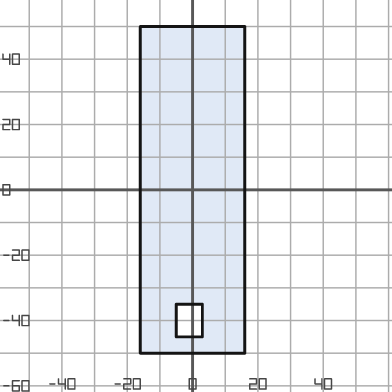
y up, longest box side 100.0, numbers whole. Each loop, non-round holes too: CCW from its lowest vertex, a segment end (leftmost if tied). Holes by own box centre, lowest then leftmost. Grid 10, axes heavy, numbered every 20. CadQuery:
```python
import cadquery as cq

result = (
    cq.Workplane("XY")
    .moveTo(-16.0, -50.0)
    .lineTo(16.0, -50.0)
    .lineTo(16.0, 50.0)
    .lineTo(-16.0, 50.0)
    .close()
    .moveTo(-5.0, -45.0)
    .lineTo(3.0, -45.0)
    .lineTo(3.0, -35.0)
    .lineTo(-5.0, -35.0)
    .close()
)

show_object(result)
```